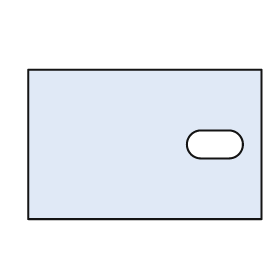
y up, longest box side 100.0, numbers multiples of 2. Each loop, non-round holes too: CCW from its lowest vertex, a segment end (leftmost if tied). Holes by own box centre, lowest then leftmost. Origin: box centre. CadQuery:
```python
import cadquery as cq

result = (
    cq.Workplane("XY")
    .moveTo(-50.0, -32.0)
    .lineTo(50.0, -32.0)
    .lineTo(50.0, 32.0)
    .lineTo(-50.0, 32.0)
    .close()
    .moveTo(24.0, -6.0)
    .lineTo(36.0, -6.0)
    .threePointArc((42.0, 0.0), (36.0, 6.0))
    .lineTo(24.0, 6.0)
    .threePointArc((18.0, 0.0), (24.0, -6.0))
    .close()
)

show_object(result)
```